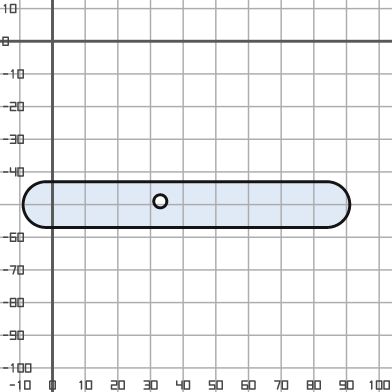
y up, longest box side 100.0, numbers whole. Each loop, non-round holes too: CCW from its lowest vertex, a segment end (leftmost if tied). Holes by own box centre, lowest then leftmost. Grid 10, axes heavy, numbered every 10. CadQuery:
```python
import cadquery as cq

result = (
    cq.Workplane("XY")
    .moveTo(-2.0, -57.0)
    .lineTo(84.0, -57.0)
    .threePointArc((91.0, -50.0), (84.0, -43.0))
    .lineTo(-2.0, -43.0)
    .threePointArc((-9.0, -50.0), (-2.0, -57.0))
    .close()
    .moveTo(33.0, -49.0)
    .circle(2.0)
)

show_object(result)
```